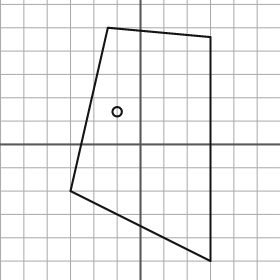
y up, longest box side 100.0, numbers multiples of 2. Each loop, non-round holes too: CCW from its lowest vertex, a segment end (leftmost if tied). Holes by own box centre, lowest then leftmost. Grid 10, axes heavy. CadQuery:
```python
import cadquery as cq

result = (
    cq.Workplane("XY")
    .moveTo(30.0, -50.0)
    .lineTo(30.0, 46.0)
    .lineTo(-14.0, 50.0)
    .lineTo(-30.0, -20.0)
    .close()
    .moveTo(-10.0, 14.0)
    .circle(2.0)
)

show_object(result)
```